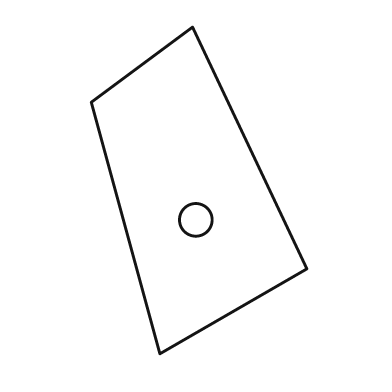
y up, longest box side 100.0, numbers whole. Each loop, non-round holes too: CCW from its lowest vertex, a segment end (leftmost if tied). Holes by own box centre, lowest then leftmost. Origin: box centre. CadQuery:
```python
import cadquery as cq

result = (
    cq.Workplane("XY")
    .moveTo(-12.0, -50.0)
    .lineTo(33.0, -24.0)
    .lineTo(-2.0, 50.0)
    .lineTo(-33.0, 27.0)
    .close()
    .moveTo(-1.0, -9.0)
    .circle(5.0)
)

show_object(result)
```